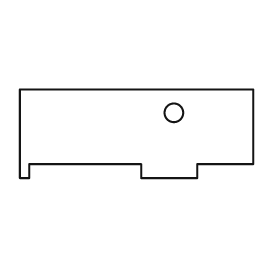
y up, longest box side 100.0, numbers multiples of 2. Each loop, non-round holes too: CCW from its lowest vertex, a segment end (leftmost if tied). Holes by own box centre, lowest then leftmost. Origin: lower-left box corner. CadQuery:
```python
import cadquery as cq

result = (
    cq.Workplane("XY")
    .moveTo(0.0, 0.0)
    .lineTo(4.0, 0.0)
    .lineTo(4.0, 6.0)
    .lineTo(52.0, 6.0)
    .lineTo(52.0, 0.0)
    .lineTo(76.0, 0.0)
    .lineTo(76.0, 6.0)
    .lineTo(100.0, 6.0)
    .lineTo(100.0, 38.0)
    .lineTo(0.0, 38.0)
    .close()
    .moveTo(66.0, 28.0)
    .circle(4.0)
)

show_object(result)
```